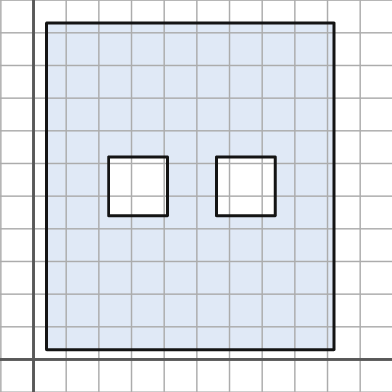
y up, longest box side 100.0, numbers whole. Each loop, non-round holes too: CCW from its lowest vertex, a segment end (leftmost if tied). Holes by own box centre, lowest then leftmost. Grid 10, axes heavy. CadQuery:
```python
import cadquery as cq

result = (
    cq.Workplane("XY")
    .moveTo(4.0, 3.0)
    .lineTo(92.0, 3.0)
    .lineTo(92.0, 103.0)
    .lineTo(4.0, 103.0)
    .close()
    .moveTo(23.0, 44.0)
    .lineTo(41.0, 44.0)
    .lineTo(41.0, 62.0)
    .lineTo(23.0, 62.0)
    .close()
    .moveTo(56.0, 44.0)
    .lineTo(74.0, 44.0)
    .lineTo(74.0, 62.0)
    .lineTo(56.0, 62.0)
    .close()
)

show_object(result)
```